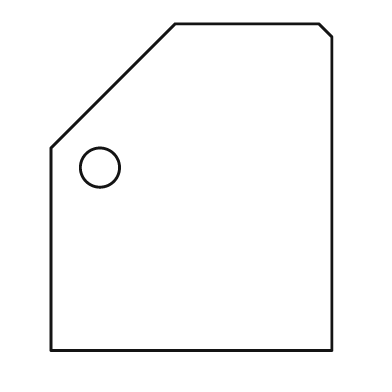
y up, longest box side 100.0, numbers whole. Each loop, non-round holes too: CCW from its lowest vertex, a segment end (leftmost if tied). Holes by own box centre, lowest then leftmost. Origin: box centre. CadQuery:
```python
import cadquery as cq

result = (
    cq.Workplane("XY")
    .moveTo(-43.0, -50.0)
    .lineTo(43.0, -50.0)
    .lineTo(43.0, 46.0)
    .lineTo(39.0, 50.0)
    .lineTo(-5.0, 50.0)
    .lineTo(-43.0, 12.0)
    .close()
    .moveTo(-28.0, 6.0)
    .circle(6.0)
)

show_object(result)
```